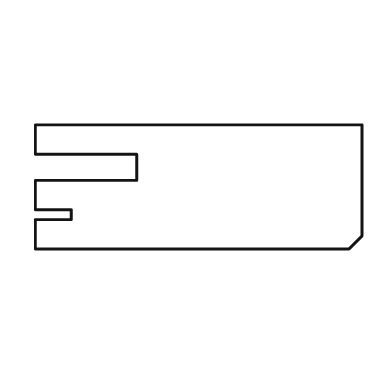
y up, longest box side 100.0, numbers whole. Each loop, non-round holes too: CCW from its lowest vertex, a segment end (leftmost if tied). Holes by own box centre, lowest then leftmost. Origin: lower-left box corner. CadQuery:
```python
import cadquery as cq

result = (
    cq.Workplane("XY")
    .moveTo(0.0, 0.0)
    .lineTo(96.0, 0.0)
    .lineTo(100.0, 4.0)
    .lineTo(100.0, 38.0)
    .lineTo(0.0, 38.0)
    .lineTo(0.0, 29.0)
    .lineTo(31.0, 29.0)
    .lineTo(31.0, 21.0)
    .lineTo(0.0, 21.0)
    .lineTo(0.0, 12.0)
    .lineTo(11.0, 12.0)
    .lineTo(11.0, 9.0)
    .lineTo(0.0, 9.0)
    .close()
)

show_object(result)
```